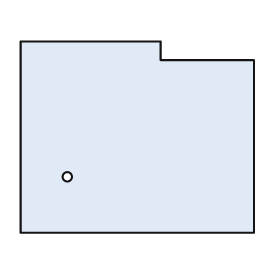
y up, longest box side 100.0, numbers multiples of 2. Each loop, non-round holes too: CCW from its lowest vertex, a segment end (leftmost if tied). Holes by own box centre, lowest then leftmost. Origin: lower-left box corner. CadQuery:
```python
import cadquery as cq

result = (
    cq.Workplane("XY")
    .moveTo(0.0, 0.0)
    .lineTo(100.0, 0.0)
    .lineTo(100.0, 74.0)
    .lineTo(60.0, 74.0)
    .lineTo(60.0, 82.0)
    .lineTo(0.0, 82.0)
    .close()
    .moveTo(20.0, 24.0)
    .circle(2.0)
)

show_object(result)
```